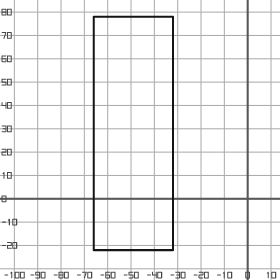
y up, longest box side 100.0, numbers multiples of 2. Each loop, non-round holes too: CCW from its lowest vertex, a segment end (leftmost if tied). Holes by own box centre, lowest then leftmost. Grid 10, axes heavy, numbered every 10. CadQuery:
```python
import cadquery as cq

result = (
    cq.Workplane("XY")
    .moveTo(-66.0, -22.0)
    .lineTo(-32.0, -22.0)
    .lineTo(-32.0, 78.0)
    .lineTo(-66.0, 78.0)
    .close()
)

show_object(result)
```